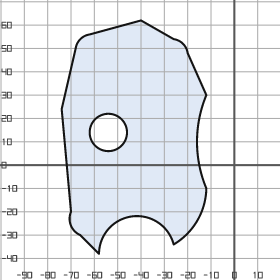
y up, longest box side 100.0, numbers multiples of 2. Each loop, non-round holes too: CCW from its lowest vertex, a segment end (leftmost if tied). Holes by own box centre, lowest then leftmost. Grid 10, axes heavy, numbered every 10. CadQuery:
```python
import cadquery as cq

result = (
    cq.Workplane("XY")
    .moveTo(-58.0, -38.0)
    .threePointArc((-44.0, -22.0), (-26.0, -34.0))
    .threePointArc((-16.0, -24.0), (-12.0, -10.0))
    .threePointArc((-16.0, 10.0), (-12.0, 30.0))
    .lineTo(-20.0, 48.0)
    .threePointArc((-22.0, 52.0), (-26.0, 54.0))
    .lineTo(-40.0, 62.0)
    .lineTo(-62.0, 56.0)
    .threePointArc((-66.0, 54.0), (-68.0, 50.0))
    .lineTo(-74.0, 24.0)
    .lineTo(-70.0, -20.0)
    .threePointArc((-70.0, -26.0), (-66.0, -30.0))
    .close()
    .moveTo(-54.0, 14.0)
    .circle(8.0)
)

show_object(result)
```